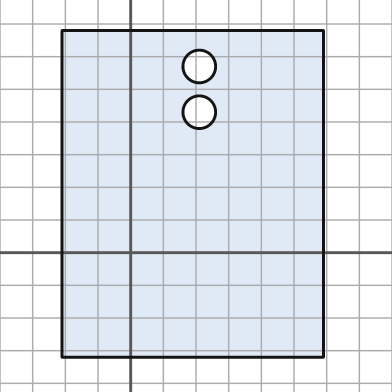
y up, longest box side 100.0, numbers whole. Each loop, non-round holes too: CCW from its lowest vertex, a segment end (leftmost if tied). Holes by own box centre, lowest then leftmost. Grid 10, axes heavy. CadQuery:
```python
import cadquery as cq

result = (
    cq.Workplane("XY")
    .moveTo(-21.0, -32.0)
    .lineTo(59.0, -32.0)
    .lineTo(59.0, 68.0)
    .lineTo(-21.0, 68.0)
    .close()
    .moveTo(21.0, 43.0)
    .circle(5.0)
    .moveTo(21.0, 57.0)
    .circle(5.0)
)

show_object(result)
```